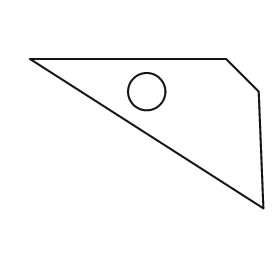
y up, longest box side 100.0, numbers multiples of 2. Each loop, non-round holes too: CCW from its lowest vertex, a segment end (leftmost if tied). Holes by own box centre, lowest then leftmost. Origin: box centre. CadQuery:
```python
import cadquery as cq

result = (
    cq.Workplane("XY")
    .moveTo(50.0, -32.0)
    .lineTo(48.0, 18.0)
    .lineTo(34.0, 32.0)
    .lineTo(-50.0, 32.0)
    .close()
    .moveTo(0.0, 18.0)
    .circle(8.0)
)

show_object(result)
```